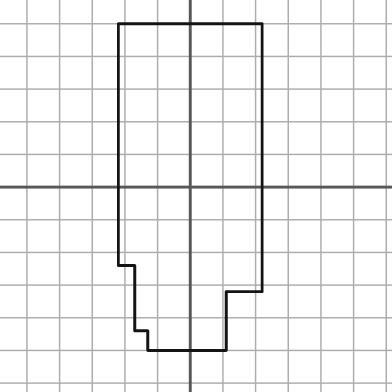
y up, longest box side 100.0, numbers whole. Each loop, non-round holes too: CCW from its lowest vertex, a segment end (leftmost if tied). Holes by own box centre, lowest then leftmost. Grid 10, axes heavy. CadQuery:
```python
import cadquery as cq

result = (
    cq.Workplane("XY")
    .moveTo(-13.0, -50.0)
    .lineTo(11.0, -50.0)
    .lineTo(11.0, -32.0)
    .lineTo(22.0, -32.0)
    .lineTo(22.0, 50.0)
    .lineTo(-22.0, 50.0)
    .lineTo(-22.0, -24.0)
    .lineTo(-17.0, -24.0)
    .lineTo(-17.0, -44.0)
    .lineTo(-13.0, -44.0)
    .close()
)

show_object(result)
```